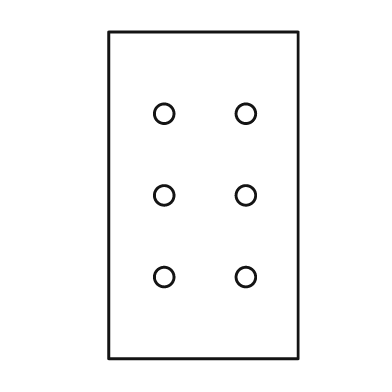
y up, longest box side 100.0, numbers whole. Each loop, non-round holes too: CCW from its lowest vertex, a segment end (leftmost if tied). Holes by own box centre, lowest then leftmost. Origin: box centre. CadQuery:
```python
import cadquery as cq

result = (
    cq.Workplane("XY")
    .moveTo(-29.0, -50.0)
    .lineTo(29.0, -50.0)
    .lineTo(29.0, 50.0)
    .lineTo(-29.0, 50.0)
    .close()
    .moveTo(-12.0, -25.0)
    .circle(3.0)
    .moveTo(13.0, -25.0)
    .circle(3.0)
    .moveTo(-12.0, 0.0)
    .circle(3.0)
    .moveTo(13.0, 0.0)
    .circle(3.0)
    .moveTo(-12.0, 25.0)
    .circle(3.0)
    .moveTo(13.0, 25.0)
    .circle(3.0)
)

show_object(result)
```